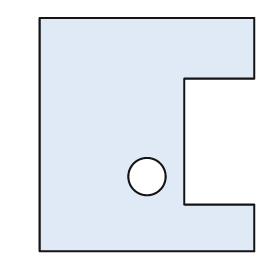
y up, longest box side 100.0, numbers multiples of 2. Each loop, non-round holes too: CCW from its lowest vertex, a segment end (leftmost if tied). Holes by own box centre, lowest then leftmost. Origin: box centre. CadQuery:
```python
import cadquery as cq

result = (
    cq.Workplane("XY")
    .moveTo(-46.0, -50.0)
    .lineTo(46.0, -50.0)
    .lineTo(46.0, -30.0)
    .lineTo(16.0, -30.0)
    .lineTo(16.0, 24.0)
    .lineTo(46.0, 24.0)
    .lineTo(46.0, 50.0)
    .lineTo(-46.0, 50.0)
    .close()
    .moveTo(0.0, -18.0)
    .circle(8.0)
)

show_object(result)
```